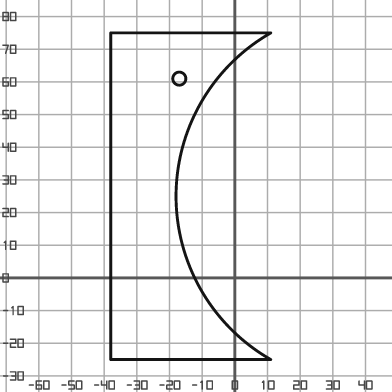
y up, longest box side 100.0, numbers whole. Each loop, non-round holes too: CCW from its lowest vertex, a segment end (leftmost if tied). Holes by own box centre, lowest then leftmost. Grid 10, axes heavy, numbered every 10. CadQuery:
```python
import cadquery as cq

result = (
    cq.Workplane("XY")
    .moveTo(-38.0, -25.0)
    .lineTo(11.0, -25.0)
    .threePointArc((-18.0, 25.0), (11.0, 75.0))
    .lineTo(-38.0, 75.0)
    .close()
    .moveTo(-17.0, 61.0)
    .circle(2.0)
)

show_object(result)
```